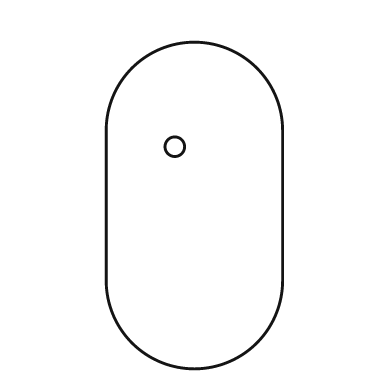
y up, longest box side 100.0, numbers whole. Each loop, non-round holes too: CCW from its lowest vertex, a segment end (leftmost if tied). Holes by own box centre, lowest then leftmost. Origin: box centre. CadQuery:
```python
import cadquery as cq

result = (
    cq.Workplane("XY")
    .moveTo(-27.0, -23.0)
    .threePointArc((0.0, -50.0), (27.0, -23.0))
    .lineTo(27.0, 23.0)
    .threePointArc((0.0, 50.0), (-27.0, 23.0))
    .close()
    .moveTo(-6.0, 18.0)
    .circle(3.0)
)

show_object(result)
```